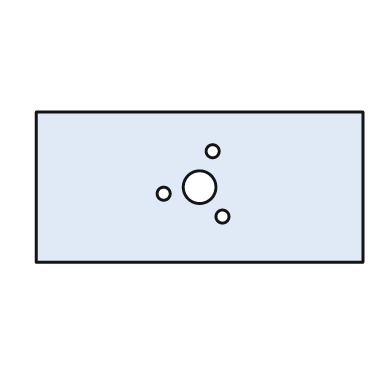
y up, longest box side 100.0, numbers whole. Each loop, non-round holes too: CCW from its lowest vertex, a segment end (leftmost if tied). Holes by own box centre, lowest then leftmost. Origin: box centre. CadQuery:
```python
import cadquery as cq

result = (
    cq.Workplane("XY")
    .moveTo(-50.0, -23.0)
    .lineTo(50.0, -23.0)
    .lineTo(50.0, 23.0)
    .lineTo(-50.0, 23.0)
    .close()
    .moveTo(7.0, -9.0)
    .circle(2.0)
    .moveTo(-11.0, -2.0)
    .circle(2.0)
    .moveTo(0.0, 0.0)
    .circle(5.0)
    .moveTo(4.0, 11.0)
    .circle(2.0)
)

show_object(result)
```